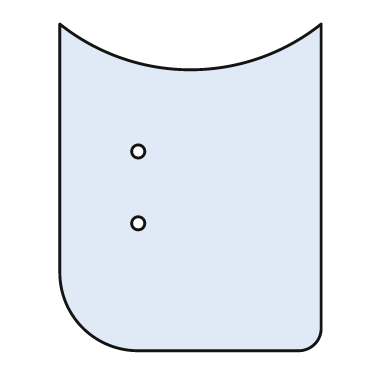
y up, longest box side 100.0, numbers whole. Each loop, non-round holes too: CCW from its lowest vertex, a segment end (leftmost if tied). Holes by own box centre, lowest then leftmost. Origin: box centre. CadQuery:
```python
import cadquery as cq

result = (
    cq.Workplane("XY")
    .moveTo(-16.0, -50.0)
    .lineTo(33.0, -50.0)
    .threePointArc((38.0, -48.0), (40.0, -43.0))
    .lineTo(40.0, 50.0)
    .threePointArc((0.0, 36.0), (-40.0, 50.0))
    .lineTo(-40.0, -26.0)
    .threePointArc((-33.0, -43.0), (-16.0, -50.0))
    .close()
    .moveTo(-16.0, -11.0)
    .circle(2.0)
    .moveTo(-16.0, 11.0)
    .circle(2.0)
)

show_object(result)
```